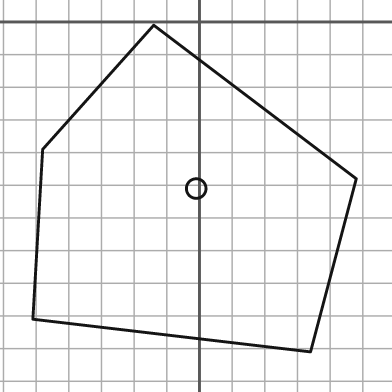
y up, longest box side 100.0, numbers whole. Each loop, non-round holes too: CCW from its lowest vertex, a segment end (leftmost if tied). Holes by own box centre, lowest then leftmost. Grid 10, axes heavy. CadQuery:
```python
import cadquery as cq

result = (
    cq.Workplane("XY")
    .moveTo(34.0, -101.0)
    .lineTo(48.0, -48.0)
    .lineTo(-14.0, -1.0)
    .lineTo(-48.0, -39.0)
    .lineTo(-51.0, -91.0)
    .close()
    .moveTo(-1.0, -51.0)
    .circle(3.0)
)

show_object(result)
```